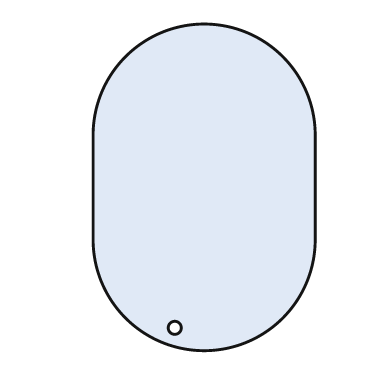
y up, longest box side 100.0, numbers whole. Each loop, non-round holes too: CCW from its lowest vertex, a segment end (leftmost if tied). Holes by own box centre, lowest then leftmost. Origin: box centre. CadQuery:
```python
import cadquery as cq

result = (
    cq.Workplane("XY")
    .moveTo(-34.0, -16.0)
    .threePointArc((0.0, -50.0), (34.0, -16.0))
    .lineTo(34.0, 16.0)
    .threePointArc((0.0, 50.0), (-34.0, 16.0))
    .close()
    .moveTo(-9.0, -43.0)
    .circle(2.0)
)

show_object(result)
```